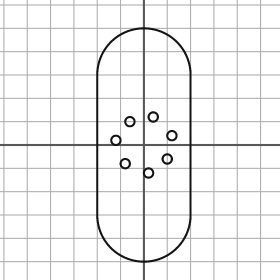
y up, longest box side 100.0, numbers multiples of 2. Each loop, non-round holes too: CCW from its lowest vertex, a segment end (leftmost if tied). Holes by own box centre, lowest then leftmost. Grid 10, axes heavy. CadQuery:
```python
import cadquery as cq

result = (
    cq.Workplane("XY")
    .moveTo(-20.0, -30.0)
    .threePointArc((0.0, -50.0), (20.0, -30.0))
    .lineTo(20.0, 30.0)
    .threePointArc((0.0, 50.0), (-20.0, 30.0))
    .close()
    .moveTo(2.0, -12.0)
    .circle(2.0)
    .moveTo(-8.0, -8.0)
    .circle(2.0)
    .moveTo(10.0, -6.0)
    .circle(2.0)
    .moveTo(-12.0, 2.0)
    .circle(2.0)
    .moveTo(12.0, 4.0)
    .circle(2.0)
    .moveTo(-6.0, 10.0)
    .circle(2.0)
    .moveTo(4.0, 12.0)
    .circle(2.0)
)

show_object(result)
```